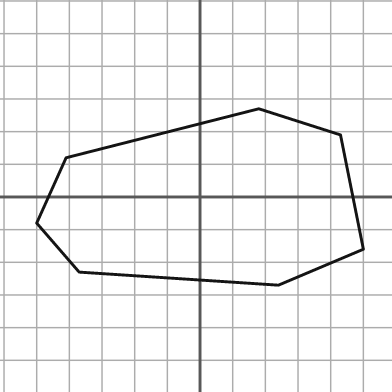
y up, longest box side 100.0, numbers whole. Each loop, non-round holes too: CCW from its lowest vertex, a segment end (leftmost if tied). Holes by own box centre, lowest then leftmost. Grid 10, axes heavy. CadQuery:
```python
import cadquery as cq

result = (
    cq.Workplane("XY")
    .moveTo(24.0, -27.0)
    .lineTo(50.0, -16.0)
    .lineTo(43.0, 19.0)
    .lineTo(18.0, 27.0)
    .lineTo(-41.0, 12.0)
    .lineTo(-50.0, -8.0)
    .lineTo(-37.0, -23.0)
    .close()
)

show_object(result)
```